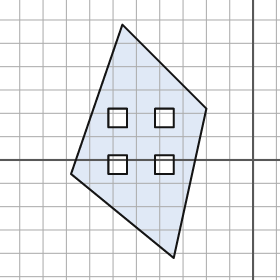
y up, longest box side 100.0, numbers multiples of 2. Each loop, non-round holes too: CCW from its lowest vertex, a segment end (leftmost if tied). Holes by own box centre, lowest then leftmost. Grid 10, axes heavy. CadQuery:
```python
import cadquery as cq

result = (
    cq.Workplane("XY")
    .moveTo(-34.0, -42.0)
    .lineTo(-20.0, 22.0)
    .lineTo(-56.0, 58.0)
    .lineTo(-78.0, -6.0)
    .close()
    .moveTo(-62.0, -6.0)
    .lineTo(-54.0, -6.0)
    .lineTo(-54.0, 2.0)
    .lineTo(-62.0, 2.0)
    .close()
    .moveTo(-42.0, -6.0)
    .lineTo(-34.0, -6.0)
    .lineTo(-34.0, 2.0)
    .lineTo(-42.0, 2.0)
    .close()
    .moveTo(-62.0, 14.0)
    .lineTo(-54.0, 14.0)
    .lineTo(-54.0, 22.0)
    .lineTo(-62.0, 22.0)
    .close()
    .moveTo(-42.0, 14.0)
    .lineTo(-34.0, 14.0)
    .lineTo(-34.0, 22.0)
    .lineTo(-42.0, 22.0)
    .close()
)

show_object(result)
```